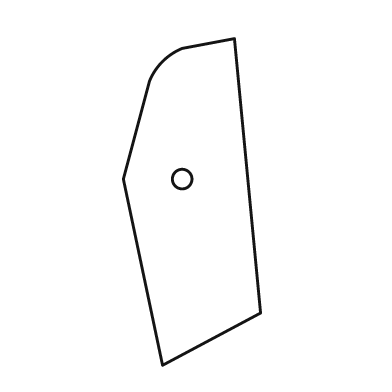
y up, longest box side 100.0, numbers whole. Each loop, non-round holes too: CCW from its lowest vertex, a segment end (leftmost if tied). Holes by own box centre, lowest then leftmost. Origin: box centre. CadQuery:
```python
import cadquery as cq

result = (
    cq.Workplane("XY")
    .moveTo(-9.0, -50.0)
    .lineTo(21.0, -34.0)
    .lineTo(13.0, 50.0)
    .lineTo(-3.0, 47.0)
    .threePointArc((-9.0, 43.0), (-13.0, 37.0))
    .lineTo(-21.0, 7.0)
    .close()
    .moveTo(-3.0, 7.0)
    .circle(3.0)
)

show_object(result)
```